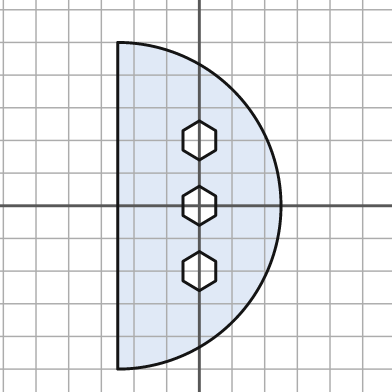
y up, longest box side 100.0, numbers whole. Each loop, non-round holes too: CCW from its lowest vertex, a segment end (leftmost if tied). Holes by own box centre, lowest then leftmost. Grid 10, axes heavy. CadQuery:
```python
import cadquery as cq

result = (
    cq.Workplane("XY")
    .moveTo(-25.0, -50.0)
    .threePointArc((25.0, 0.0), (-25.0, 50.0))
    .close()
    .moveTo(0.0, -26.0)
    .lineTo(5.0, -23.0)
    .lineTo(5.0, -17.0)
    .lineTo(0.0, -14.0)
    .lineTo(-5.0, -17.0)
    .lineTo(-5.0, -23.0)
    .close()
    .moveTo(0.0, -6.0)
    .lineTo(5.0, -3.0)
    .lineTo(5.0, 3.0)
    .lineTo(0.0, 6.0)
    .lineTo(-5.0, 3.0)
    .lineTo(-5.0, -3.0)
    .close()
    .moveTo(0.0, 14.0)
    .lineTo(5.0, 17.0)
    .lineTo(5.0, 23.0)
    .lineTo(0.0, 26.0)
    .lineTo(-5.0, 23.0)
    .lineTo(-5.0, 17.0)
    .close()
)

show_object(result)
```